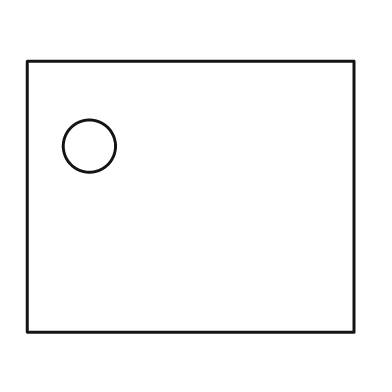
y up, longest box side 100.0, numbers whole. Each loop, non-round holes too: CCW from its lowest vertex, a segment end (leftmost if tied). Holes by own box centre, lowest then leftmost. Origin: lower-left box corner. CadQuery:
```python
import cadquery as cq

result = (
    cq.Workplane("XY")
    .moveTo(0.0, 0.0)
    .lineTo(100.0, 0.0)
    .lineTo(100.0, 83.0)
    .lineTo(0.0, 83.0)
    .close()
    .moveTo(19.0, 57.0)
    .circle(8.0)
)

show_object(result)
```